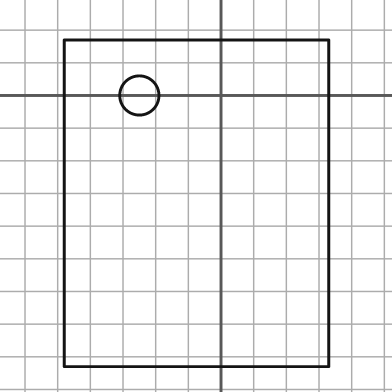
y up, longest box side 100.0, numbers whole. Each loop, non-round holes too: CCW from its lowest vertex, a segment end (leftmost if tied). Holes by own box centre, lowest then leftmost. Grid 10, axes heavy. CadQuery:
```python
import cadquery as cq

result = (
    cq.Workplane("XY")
    .moveTo(-48.0, -83.0)
    .lineTo(33.0, -83.0)
    .lineTo(33.0, 17.0)
    .lineTo(-48.0, 17.0)
    .close()
    .moveTo(-25.0, 0.0)
    .circle(6.0)
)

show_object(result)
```